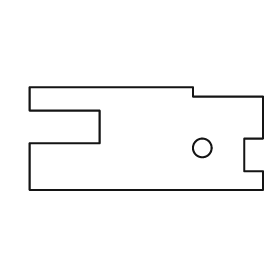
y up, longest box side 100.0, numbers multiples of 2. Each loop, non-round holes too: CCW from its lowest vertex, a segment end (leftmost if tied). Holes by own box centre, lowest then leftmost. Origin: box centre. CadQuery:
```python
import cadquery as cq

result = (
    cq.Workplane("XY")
    .moveTo(-50.0, -22.0)
    .lineTo(50.0, -22.0)
    .lineTo(50.0, -14.0)
    .lineTo(42.0, -14.0)
    .lineTo(42.0, 0.0)
    .lineTo(50.0, 0.0)
    .lineTo(50.0, 18.0)
    .lineTo(20.0, 18.0)
    .lineTo(20.0, 22.0)
    .lineTo(-50.0, 22.0)
    .lineTo(-50.0, 12.0)
    .lineTo(-20.0, 12.0)
    .lineTo(-20.0, -2.0)
    .lineTo(-50.0, -2.0)
    .close()
    .moveTo(24.0, -4.0)
    .circle(4.0)
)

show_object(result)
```